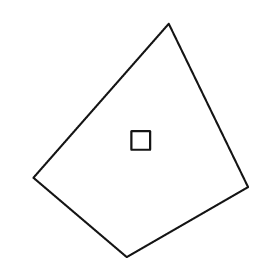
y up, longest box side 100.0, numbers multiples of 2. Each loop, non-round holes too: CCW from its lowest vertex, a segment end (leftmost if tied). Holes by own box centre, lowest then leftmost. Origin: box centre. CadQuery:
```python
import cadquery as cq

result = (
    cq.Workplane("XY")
    .moveTo(-6.0, -50.0)
    .lineTo(46.0, -20.0)
    .lineTo(12.0, 50.0)
    .lineTo(-46.0, -16.0)
    .close()
    .moveTo(-4.0, -4.0)
    .lineTo(4.0, -4.0)
    .lineTo(4.0, 4.0)
    .lineTo(-4.0, 4.0)
    .close()
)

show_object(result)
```